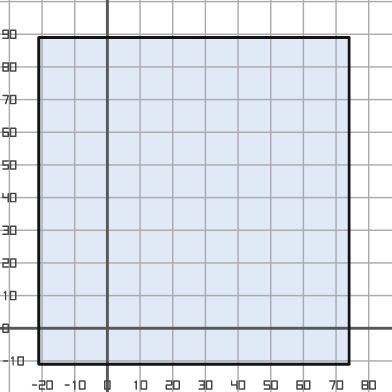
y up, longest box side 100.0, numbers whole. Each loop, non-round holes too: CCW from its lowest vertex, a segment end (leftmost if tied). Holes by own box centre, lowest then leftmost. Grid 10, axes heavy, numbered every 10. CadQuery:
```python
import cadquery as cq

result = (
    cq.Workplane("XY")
    .moveTo(-21.0, -11.0)
    .lineTo(74.0, -11.0)
    .lineTo(74.0, 89.0)
    .lineTo(-21.0, 89.0)
    .close()
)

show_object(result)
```